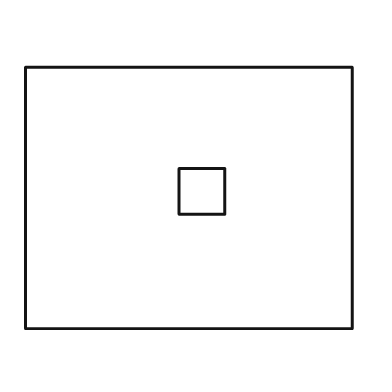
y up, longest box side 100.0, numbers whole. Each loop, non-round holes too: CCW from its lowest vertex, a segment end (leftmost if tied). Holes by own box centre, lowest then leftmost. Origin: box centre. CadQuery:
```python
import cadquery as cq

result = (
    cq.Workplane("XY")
    .moveTo(-50.0, -40.0)
    .lineTo(50.0, -40.0)
    .lineTo(50.0, 40.0)
    .lineTo(-50.0, 40.0)
    .close()
    .moveTo(-3.0, -5.0)
    .lineTo(11.0, -5.0)
    .lineTo(11.0, 9.0)
    .lineTo(-3.0, 9.0)
    .close()
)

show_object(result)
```